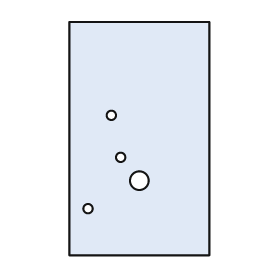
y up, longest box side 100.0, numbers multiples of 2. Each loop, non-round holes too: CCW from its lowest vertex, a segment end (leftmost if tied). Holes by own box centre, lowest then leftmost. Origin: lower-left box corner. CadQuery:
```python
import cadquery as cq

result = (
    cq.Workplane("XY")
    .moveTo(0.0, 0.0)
    .lineTo(60.0, 0.0)
    .lineTo(60.0, 100.0)
    .lineTo(0.0, 100.0)
    .close()
    .moveTo(8.0, 20.0)
    .circle(2.0)
    .moveTo(30.0, 32.0)
    .circle(4.0)
    .moveTo(22.0, 42.0)
    .circle(2.0)
    .moveTo(18.0, 60.0)
    .circle(2.0)
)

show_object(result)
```